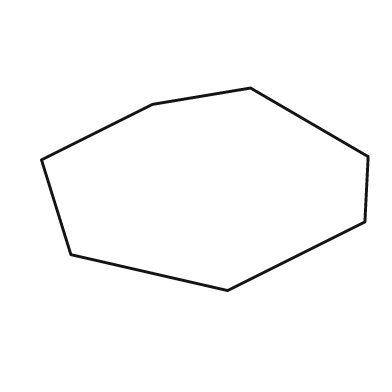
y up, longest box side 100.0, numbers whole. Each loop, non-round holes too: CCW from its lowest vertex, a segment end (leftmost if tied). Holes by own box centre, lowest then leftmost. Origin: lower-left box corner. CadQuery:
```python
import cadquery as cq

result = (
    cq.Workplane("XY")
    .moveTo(57.0, 0.0)
    .lineTo(99.0, 21.0)
    .lineTo(100.0, 41.0)
    .lineTo(64.0, 62.0)
    .lineTo(34.0, 57.0)
    .lineTo(0.0, 40.0)
    .lineTo(9.0, 11.0)
    .close()
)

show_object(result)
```